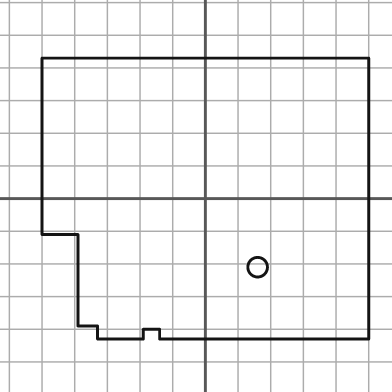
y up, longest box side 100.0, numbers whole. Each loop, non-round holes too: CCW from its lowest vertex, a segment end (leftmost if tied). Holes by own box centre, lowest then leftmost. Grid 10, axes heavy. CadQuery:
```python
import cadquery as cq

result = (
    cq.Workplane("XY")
    .moveTo(-33.0, -43.0)
    .lineTo(-19.0, -43.0)
    .lineTo(-19.0, -40.0)
    .lineTo(-14.0, -40.0)
    .lineTo(-14.0, -43.0)
    .lineTo(50.0, -43.0)
    .lineTo(50.0, 43.0)
    .lineTo(-50.0, 43.0)
    .lineTo(-50.0, -11.0)
    .lineTo(-39.0, -11.0)
    .lineTo(-39.0, -39.0)
    .lineTo(-33.0, -39.0)
    .close()
    .moveTo(16.0, -21.0)
    .circle(3.0)
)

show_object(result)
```